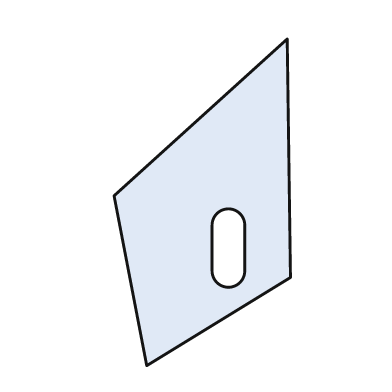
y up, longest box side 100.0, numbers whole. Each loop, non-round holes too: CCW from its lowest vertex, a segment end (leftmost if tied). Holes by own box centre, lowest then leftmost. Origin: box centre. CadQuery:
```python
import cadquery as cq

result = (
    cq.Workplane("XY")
    .moveTo(-17.0, -50.0)
    .lineTo(27.0, -23.0)
    .lineTo(26.0, 50.0)
    .lineTo(-27.0, 2.0)
    .close()
    .moveTo(3.0, -21.0)
    .threePointArc((8.0, -26.0), (13.0, -21.0))
    .lineTo(13.0, -7.0)
    .threePointArc((8.0, -2.0), (3.0, -7.0))
    .close()
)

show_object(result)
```